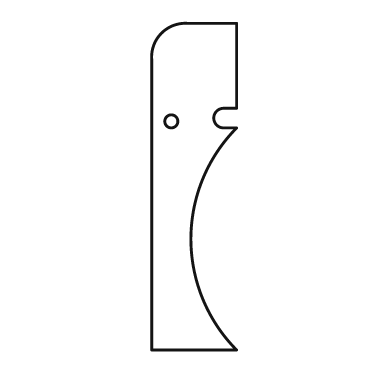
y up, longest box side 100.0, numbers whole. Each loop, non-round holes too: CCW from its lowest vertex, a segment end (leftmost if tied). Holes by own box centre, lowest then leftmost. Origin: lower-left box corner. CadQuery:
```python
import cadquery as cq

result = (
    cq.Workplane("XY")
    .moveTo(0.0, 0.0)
    .lineTo(26.0, 0.0)
    .threePointArc((12.0, 34.0), (26.0, 68.0))
    .lineTo(22.0, 68.0)
    .threePointArc((19.0, 71.0), (22.0, 74.0))
    .lineTo(26.0, 74.0)
    .lineTo(26.0, 100.0)
    .lineTo(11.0, 100.0)
    .threePointArc((3.0, 97.0), (0.0, 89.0))
    .close()
    .moveTo(6.0, 70.0)
    .circle(2.0)
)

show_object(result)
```